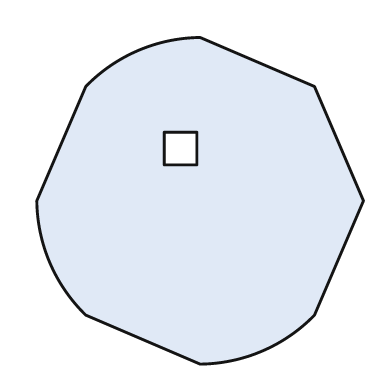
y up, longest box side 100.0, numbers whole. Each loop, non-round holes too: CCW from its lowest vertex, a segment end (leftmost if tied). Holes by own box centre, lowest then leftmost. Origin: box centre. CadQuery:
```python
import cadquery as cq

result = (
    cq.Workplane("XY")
    .moveTo(0.0, -50.0)
    .threePointArc((19.0, -46.0), (35.0, -35.0))
    .lineTo(50.0, 0.0)
    .lineTo(35.0, 35.0)
    .lineTo(0.0, 50.0)
    .threePointArc((-19.0, 46.0), (-35.0, 35.0))
    .lineTo(-50.0, 0.0)
    .threePointArc((-46.0, -19.0), (-35.0, -35.0))
    .close()
    .moveTo(-11.0, 11.0)
    .lineTo(-1.0, 11.0)
    .lineTo(-1.0, 21.0)
    .lineTo(-11.0, 21.0)
    .close()
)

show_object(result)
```